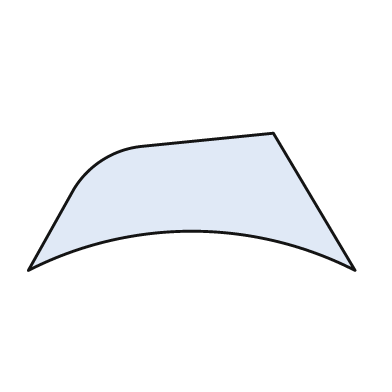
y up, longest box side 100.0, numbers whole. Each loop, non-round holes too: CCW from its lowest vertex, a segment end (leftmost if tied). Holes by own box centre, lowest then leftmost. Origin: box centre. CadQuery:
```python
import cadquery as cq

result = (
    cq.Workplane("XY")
    .moveTo(-50.0, -21.0)
    .threePointArc((0.0, -9.0), (50.0, -21.0))
    .lineTo(25.0, 21.0)
    .lineTo(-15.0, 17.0)
    .threePointArc((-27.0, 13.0), (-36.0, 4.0))
    .close()
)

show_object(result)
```